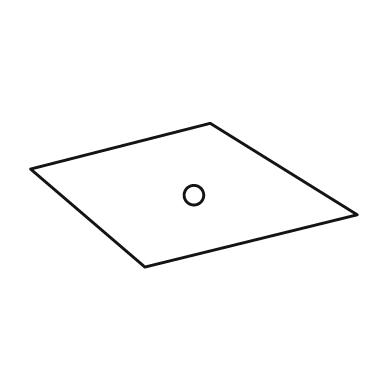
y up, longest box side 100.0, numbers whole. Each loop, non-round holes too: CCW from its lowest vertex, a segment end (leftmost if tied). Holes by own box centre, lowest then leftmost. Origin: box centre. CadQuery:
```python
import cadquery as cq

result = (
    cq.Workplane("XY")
    .moveTo(-15.0, -22.0)
    .lineTo(50.0, -6.0)
    .lineTo(5.0, 22.0)
    .lineTo(-50.0, 8.0)
    .close()
    .moveTo(0.0, 0.0)
    .circle(3.0)
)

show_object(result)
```